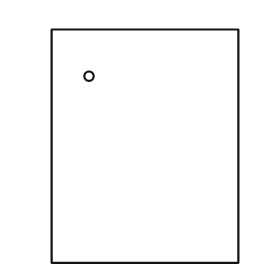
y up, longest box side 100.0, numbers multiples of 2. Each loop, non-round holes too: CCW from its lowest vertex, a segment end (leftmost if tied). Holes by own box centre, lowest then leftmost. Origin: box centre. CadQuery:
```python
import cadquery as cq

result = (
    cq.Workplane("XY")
    .moveTo(-40.0, -50.0)
    .lineTo(40.0, -50.0)
    .lineTo(40.0, 50.0)
    .lineTo(-40.0, 50.0)
    .close()
    .moveTo(-24.0, 30.0)
    .circle(2.0)
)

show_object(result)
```